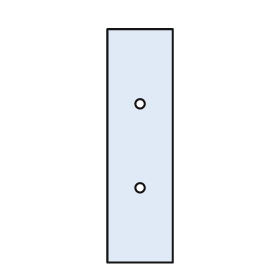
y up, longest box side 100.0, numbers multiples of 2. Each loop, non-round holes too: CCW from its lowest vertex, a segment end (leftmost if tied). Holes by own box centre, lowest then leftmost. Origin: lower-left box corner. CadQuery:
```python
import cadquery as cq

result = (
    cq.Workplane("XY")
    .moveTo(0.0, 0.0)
    .lineTo(28.0, 0.0)
    .lineTo(28.0, 100.0)
    .lineTo(0.0, 100.0)
    .close()
    .moveTo(14.0, 32.0)
    .circle(2.0)
    .moveTo(14.0, 68.0)
    .circle(2.0)
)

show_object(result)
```